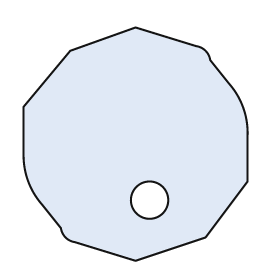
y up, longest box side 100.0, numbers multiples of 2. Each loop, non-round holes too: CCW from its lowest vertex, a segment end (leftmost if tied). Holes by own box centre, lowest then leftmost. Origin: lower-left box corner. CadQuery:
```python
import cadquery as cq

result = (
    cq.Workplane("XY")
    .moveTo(48.0, 0.0)
    .lineTo(78.0, 10.0)
    .lineTo(96.0, 34.0)
    .lineTo(96.0, 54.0)
    .threePointArc((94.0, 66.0), (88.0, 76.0))
    .lineTo(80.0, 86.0)
    .threePointArc((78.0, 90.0), (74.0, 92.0))
    .lineTo(48.0, 100.0)
    .lineTo(20.0, 90.0)
    .lineTo(0.0, 66.0)
    .lineTo(0.0, 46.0)
    .threePointArc((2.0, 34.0), (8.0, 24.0))
    .lineTo(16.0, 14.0)
    .threePointArc((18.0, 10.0), (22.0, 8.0))
    .close()
    .moveTo(54.0, 26.0)
    .circle(8.0)
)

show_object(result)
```